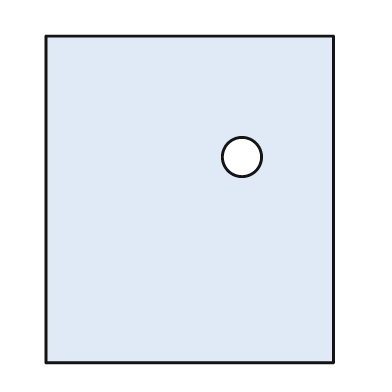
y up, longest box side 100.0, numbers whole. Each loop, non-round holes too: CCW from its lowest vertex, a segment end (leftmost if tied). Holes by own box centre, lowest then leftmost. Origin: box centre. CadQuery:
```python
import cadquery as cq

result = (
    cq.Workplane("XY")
    .moveTo(-44.0, -50.0)
    .lineTo(44.0, -50.0)
    .lineTo(44.0, 50.0)
    .lineTo(-44.0, 50.0)
    .close()
    .moveTo(16.0, 13.0)
    .circle(6.0)
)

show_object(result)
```